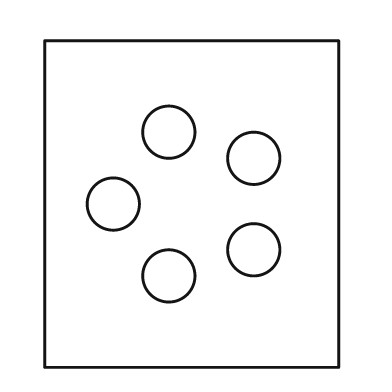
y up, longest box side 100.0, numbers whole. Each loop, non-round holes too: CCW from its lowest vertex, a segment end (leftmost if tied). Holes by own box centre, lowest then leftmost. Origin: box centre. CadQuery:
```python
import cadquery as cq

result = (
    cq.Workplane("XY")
    .moveTo(-45.0, -50.0)
    .lineTo(45.0, -50.0)
    .lineTo(45.0, 50.0)
    .lineTo(-45.0, 50.0)
    .close()
    .moveTo(-7.0, -22.0)
    .circle(8.0)
    .moveTo(19.0, -14.0)
    .circle(8.0)
    .moveTo(-24.0, 0.0)
    .circle(8.0)
    .moveTo(19.0, 14.0)
    .circle(8.0)
    .moveTo(-7.0, 22.0)
    .circle(8.0)
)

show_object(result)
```